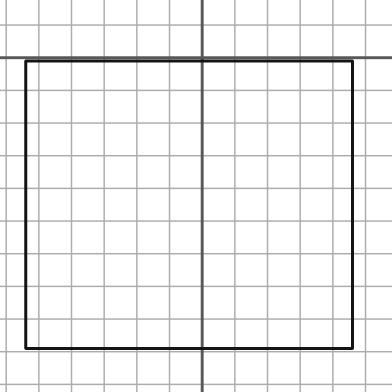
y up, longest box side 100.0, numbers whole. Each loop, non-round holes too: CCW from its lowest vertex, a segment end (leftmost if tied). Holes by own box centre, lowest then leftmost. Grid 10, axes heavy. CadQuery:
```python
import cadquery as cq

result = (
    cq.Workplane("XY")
    .moveTo(-54.0, -89.0)
    .lineTo(46.0, -89.0)
    .lineTo(46.0, -1.0)
    .lineTo(-54.0, -1.0)
    .close()
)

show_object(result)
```